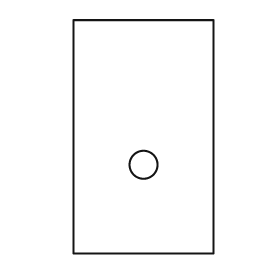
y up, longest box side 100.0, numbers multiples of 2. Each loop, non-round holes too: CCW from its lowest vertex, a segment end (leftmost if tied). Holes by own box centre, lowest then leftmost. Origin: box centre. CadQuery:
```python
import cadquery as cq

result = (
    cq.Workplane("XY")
    .moveTo(-30.0, -50.0)
    .lineTo(30.0, -50.0)
    .lineTo(30.0, 50.0)
    .lineTo(-30.0, 50.0)
    .close()
    .moveTo(0.0, -12.0)
    .circle(6.0)
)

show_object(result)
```